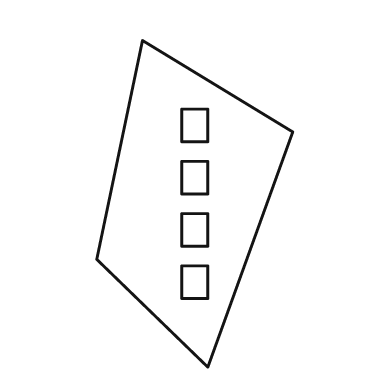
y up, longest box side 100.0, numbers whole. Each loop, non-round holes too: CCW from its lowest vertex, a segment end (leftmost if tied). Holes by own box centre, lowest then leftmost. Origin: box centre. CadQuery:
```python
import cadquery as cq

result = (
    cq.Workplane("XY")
    .moveTo(4.0, -50.0)
    .lineTo(30.0, 22.0)
    .lineTo(-16.0, 50.0)
    .lineTo(-30.0, -17.0)
    .close()
    .moveTo(-4.0, -29.0)
    .lineTo(4.0, -29.0)
    .lineTo(4.0, -19.0)
    .lineTo(-4.0, -19.0)
    .close()
    .moveTo(-4.0, -13.0)
    .lineTo(4.0, -13.0)
    .lineTo(4.0, -3.0)
    .lineTo(-4.0, -3.0)
    .close()
    .moveTo(-4.0, 3.0)
    .lineTo(4.0, 3.0)
    .lineTo(4.0, 13.0)
    .lineTo(-4.0, 13.0)
    .close()
    .moveTo(-4.0, 19.0)
    .lineTo(4.0, 19.0)
    .lineTo(4.0, 29.0)
    .lineTo(-4.0, 29.0)
    .close()
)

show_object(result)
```